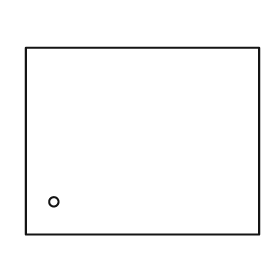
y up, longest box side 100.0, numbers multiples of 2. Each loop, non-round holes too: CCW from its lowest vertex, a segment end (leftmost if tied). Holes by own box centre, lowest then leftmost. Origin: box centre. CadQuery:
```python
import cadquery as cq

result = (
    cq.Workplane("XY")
    .moveTo(-50.0, -40.0)
    .lineTo(50.0, -40.0)
    .lineTo(50.0, 40.0)
    .lineTo(-50.0, 40.0)
    .close()
    .moveTo(-38.0, -26.0)
    .circle(2.0)
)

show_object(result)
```